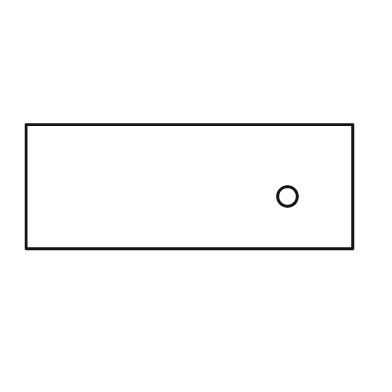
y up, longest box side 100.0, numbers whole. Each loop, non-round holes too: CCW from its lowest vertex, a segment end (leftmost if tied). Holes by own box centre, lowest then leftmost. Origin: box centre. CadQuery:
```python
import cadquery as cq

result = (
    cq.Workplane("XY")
    .moveTo(-50.0, -19.0)
    .lineTo(50.0, -19.0)
    .lineTo(50.0, 19.0)
    .lineTo(-50.0, 19.0)
    .close()
    .moveTo(30.0, -3.0)
    .circle(3.0)
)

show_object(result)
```